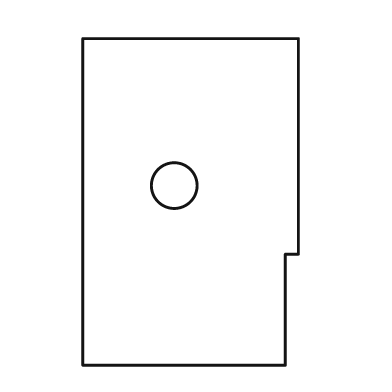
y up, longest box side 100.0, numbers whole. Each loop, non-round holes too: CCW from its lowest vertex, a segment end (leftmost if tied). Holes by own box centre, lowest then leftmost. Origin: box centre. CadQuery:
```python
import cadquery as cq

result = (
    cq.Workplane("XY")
    .moveTo(-33.0, -50.0)
    .lineTo(29.0, -50.0)
    .lineTo(29.0, -16.0)
    .lineTo(33.0, -16.0)
    .lineTo(33.0, 50.0)
    .lineTo(-33.0, 50.0)
    .close()
    .moveTo(-5.0, 5.0)
    .circle(7.0)
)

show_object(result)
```